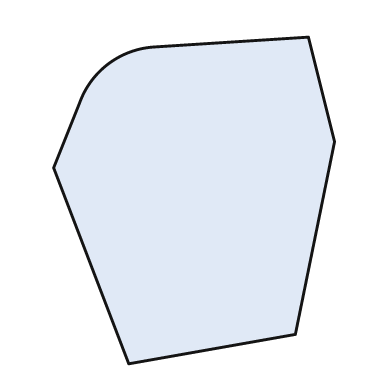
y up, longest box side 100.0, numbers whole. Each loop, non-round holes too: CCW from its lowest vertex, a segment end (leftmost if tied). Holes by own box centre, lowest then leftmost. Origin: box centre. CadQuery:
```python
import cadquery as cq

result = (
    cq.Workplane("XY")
    .moveTo(-20.0, -50.0)
    .lineTo(31.0, -41.0)
    .lineTo(43.0, 18.0)
    .lineTo(35.0, 50.0)
    .lineTo(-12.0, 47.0)
    .threePointArc((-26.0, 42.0), (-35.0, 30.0))
    .lineTo(-43.0, 10.0)
    .close()
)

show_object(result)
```